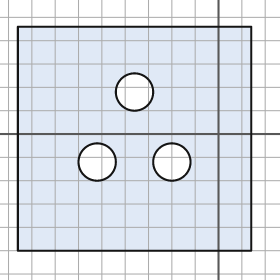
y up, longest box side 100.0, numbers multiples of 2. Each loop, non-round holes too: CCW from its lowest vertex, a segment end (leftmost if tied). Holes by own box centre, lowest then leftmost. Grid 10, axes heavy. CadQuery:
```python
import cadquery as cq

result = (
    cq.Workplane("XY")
    .moveTo(-86.0, -50.0)
    .lineTo(14.0, -50.0)
    .lineTo(14.0, 46.0)
    .lineTo(-86.0, 46.0)
    .close()
    .moveTo(-52.0, -12.0)
    .circle(8.0)
    .moveTo(-20.0, -12.0)
    .circle(8.0)
    .moveTo(-36.0, 18.0)
    .circle(8.0)
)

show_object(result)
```